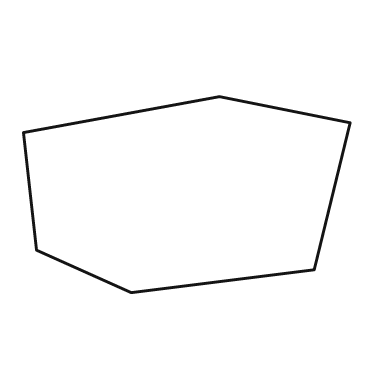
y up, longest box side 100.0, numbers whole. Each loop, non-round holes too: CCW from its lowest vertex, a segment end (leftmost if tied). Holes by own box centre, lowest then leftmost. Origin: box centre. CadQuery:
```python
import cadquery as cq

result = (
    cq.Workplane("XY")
    .moveTo(-17.0, -30.0)
    .lineTo(39.0, -23.0)
    .lineTo(50.0, 22.0)
    .lineTo(10.0, 30.0)
    .lineTo(-50.0, 19.0)
    .lineTo(-46.0, -17.0)
    .close()
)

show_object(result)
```